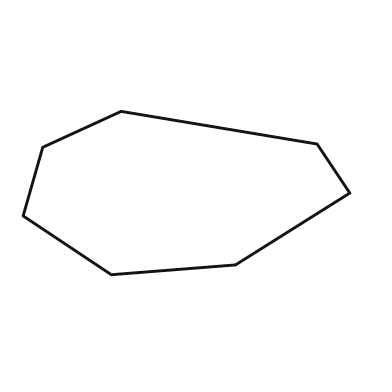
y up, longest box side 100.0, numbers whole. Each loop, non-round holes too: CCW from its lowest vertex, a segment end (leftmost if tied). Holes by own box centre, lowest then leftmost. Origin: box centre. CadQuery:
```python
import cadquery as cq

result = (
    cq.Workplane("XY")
    .moveTo(-23.0, -25.0)
    .lineTo(15.0, -22.0)
    .lineTo(50.0, 0.0)
    .lineTo(40.0, 15.0)
    .lineTo(-20.0, 25.0)
    .lineTo(-44.0, 14.0)
    .lineTo(-50.0, -7.0)
    .close()
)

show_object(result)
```